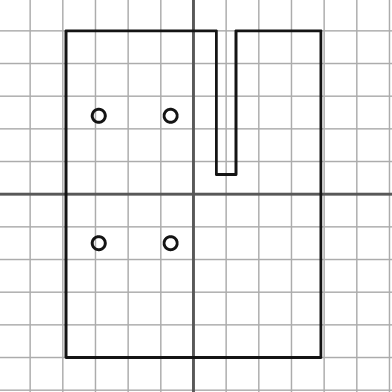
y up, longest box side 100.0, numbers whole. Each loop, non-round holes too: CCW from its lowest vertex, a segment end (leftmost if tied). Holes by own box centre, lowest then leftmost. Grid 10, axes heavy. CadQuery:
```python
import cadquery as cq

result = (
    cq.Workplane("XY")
    .moveTo(-39.0, -50.0)
    .lineTo(39.0, -50.0)
    .lineTo(39.0, 50.0)
    .lineTo(13.0, 50.0)
    .lineTo(13.0, 6.0)
    .lineTo(7.0, 6.0)
    .lineTo(7.0, 50.0)
    .lineTo(-39.0, 50.0)
    .close()
    .moveTo(-29.0, -15.0)
    .circle(2.0)
    .moveTo(-7.0, -15.0)
    .circle(2.0)
    .moveTo(-29.0, 24.0)
    .circle(2.0)
    .moveTo(-7.0, 24.0)
    .circle(2.0)
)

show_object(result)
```